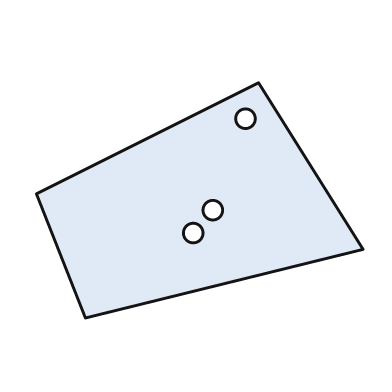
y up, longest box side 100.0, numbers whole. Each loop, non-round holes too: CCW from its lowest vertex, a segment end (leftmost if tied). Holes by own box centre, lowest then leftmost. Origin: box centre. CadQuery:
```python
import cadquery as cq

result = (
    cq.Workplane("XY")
    .moveTo(-35.0, -36.0)
    .lineTo(50.0, -15.0)
    .lineTo(18.0, 36.0)
    .lineTo(-50.0, 2.0)
    .close()
    .moveTo(-2.0, -10.0)
    .circle(3.0)
    .moveTo(4.0, -3.0)
    .circle(3.0)
    .moveTo(14.0, 25.0)
    .circle(3.0)
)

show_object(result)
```